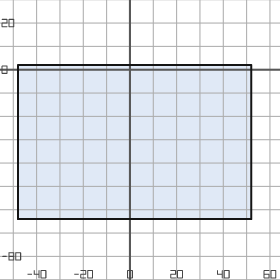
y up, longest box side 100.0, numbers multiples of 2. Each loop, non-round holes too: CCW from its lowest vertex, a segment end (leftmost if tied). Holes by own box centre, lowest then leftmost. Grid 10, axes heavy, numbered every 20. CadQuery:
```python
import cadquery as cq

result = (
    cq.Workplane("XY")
    .moveTo(-48.0, -64.0)
    .lineTo(52.0, -64.0)
    .lineTo(52.0, 2.0)
    .lineTo(-48.0, 2.0)
    .close()
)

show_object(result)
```